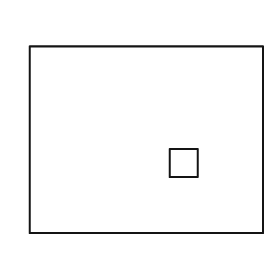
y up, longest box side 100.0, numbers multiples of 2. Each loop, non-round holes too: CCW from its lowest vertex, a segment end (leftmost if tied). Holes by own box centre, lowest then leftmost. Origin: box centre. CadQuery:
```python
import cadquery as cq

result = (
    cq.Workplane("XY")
    .moveTo(-50.0, -40.0)
    .lineTo(50.0, -40.0)
    .lineTo(50.0, 40.0)
    .lineTo(-50.0, 40.0)
    .close()
    .moveTo(10.0, -16.0)
    .lineTo(22.0, -16.0)
    .lineTo(22.0, -4.0)
    .lineTo(10.0, -4.0)
    .close()
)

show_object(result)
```